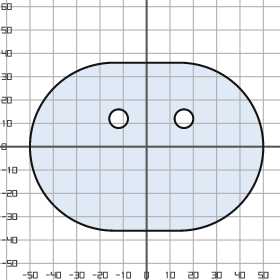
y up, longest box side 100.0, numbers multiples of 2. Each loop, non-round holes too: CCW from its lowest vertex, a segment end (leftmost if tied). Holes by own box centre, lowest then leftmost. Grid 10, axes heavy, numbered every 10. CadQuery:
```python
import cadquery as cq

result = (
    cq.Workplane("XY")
    .moveTo(-14.0, -36.0)
    .lineTo(14.0, -36.0)
    .threePointArc((50.0, 0.0), (14.0, 36.0))
    .lineTo(-14.0, 36.0)
    .threePointArc((-50.0, 0.0), (-14.0, -36.0))
    .close()
    .moveTo(-12.0, 12.0)
    .circle(4.0)
    .moveTo(16.0, 12.0)
    .circle(4.0)
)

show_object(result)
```